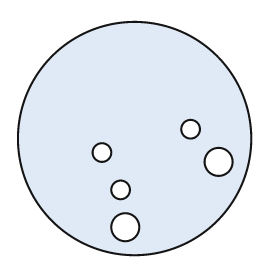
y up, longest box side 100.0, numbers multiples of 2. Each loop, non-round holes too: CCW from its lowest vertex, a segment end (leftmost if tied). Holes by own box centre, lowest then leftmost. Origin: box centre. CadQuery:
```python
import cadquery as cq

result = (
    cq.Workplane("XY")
    .moveTo(0.0, 0.0)
    .circle(50.0)
    .moveTo(-4.0, -38.0)
    .circle(6.0)
    .moveTo(-6.0, -22.0)
    .circle(4.0)
    .moveTo(36.0, -10.0)
    .circle(6.0)
    .moveTo(-14.0, -6.0)
    .circle(4.0)
    .moveTo(24.0, 4.0)
    .circle(4.0)
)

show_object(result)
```